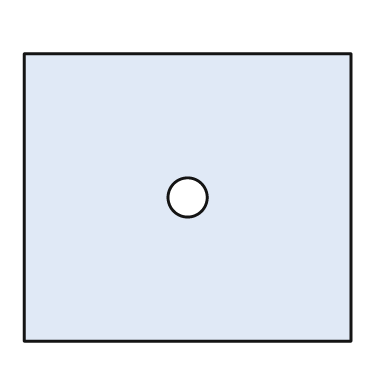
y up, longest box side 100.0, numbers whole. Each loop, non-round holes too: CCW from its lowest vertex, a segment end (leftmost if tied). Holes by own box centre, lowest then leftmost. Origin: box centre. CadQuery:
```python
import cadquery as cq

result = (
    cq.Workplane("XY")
    .moveTo(-50.0, -44.0)
    .lineTo(50.0, -44.0)
    .lineTo(50.0, 44.0)
    .lineTo(-50.0, 44.0)
    .close()
    .moveTo(0.0, 0.0)
    .circle(6.0)
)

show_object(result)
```